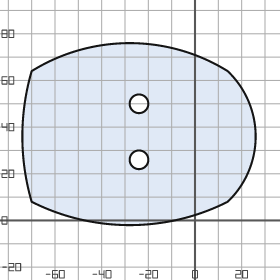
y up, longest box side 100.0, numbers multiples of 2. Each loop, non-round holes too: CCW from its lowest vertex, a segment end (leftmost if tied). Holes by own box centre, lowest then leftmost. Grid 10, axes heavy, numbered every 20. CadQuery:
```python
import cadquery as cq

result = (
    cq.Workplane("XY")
    .moveTo(-70.0, 8.0)
    .threePointArc((-28.0, -2.0), (14.0, 8.0))
    .threePointArc((26.0, 36.0), (14.0, 64.0))
    .threePointArc((-28.0, 76.0), (-70.0, 64.0))
    .threePointArc((-74.0, 36.0), (-70.0, 8.0))
    .close()
    .moveTo(-24.0, 26.0)
    .circle(4.0)
    .moveTo(-24.0, 50.0)
    .circle(4.0)
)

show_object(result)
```